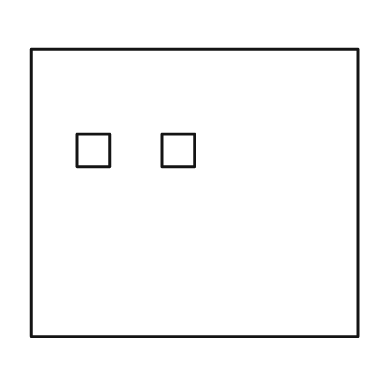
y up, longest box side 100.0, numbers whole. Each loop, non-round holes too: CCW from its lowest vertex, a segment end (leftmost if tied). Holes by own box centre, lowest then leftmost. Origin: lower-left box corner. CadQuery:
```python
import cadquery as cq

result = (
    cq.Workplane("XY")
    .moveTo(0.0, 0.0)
    .lineTo(100.0, 0.0)
    .lineTo(100.0, 88.0)
    .lineTo(0.0, 88.0)
    .close()
    .moveTo(14.0, 52.0)
    .lineTo(24.0, 52.0)
    .lineTo(24.0, 62.0)
    .lineTo(14.0, 62.0)
    .close()
    .moveTo(40.0, 52.0)
    .lineTo(50.0, 52.0)
    .lineTo(50.0, 62.0)
    .lineTo(40.0, 62.0)
    .close()
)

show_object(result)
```